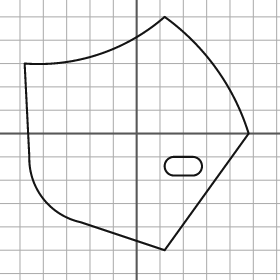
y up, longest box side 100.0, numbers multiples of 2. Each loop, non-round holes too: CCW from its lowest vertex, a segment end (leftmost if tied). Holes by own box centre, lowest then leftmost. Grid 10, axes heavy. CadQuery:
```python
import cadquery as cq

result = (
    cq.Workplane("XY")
    .moveTo(12.0, -50.0)
    .lineTo(48.0, 0.0)
    .threePointArc((34.0, 28.0), (12.0, 50.0))
    .threePointArc((-16.0, 34.0), (-48.0, 30.0))
    .lineTo(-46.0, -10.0)
    .threePointArc((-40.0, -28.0), (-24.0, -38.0))
    .close()
    .moveTo(16.0, -18.0)
    .lineTo(24.0, -18.0)
    .threePointArc((28.0, -14.0), (24.0, -10.0))
    .lineTo(16.0, -10.0)
    .threePointArc((12.0, -14.0), (16.0, -18.0))
    .close()
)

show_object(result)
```